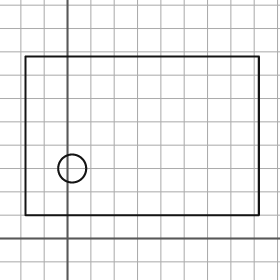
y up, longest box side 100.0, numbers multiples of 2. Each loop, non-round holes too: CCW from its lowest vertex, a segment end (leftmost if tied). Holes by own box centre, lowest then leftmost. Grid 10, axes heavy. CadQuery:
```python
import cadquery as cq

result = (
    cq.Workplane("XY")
    .moveTo(-18.0, 10.0)
    .lineTo(82.0, 10.0)
    .lineTo(82.0, 78.0)
    .lineTo(-18.0, 78.0)
    .close()
    .moveTo(2.0, 30.0)
    .circle(6.0)
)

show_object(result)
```